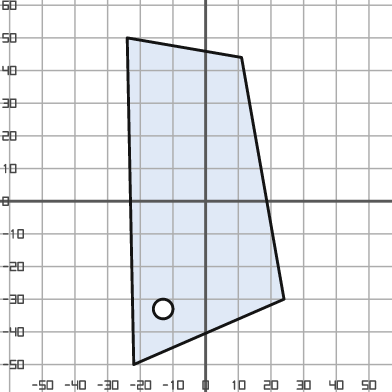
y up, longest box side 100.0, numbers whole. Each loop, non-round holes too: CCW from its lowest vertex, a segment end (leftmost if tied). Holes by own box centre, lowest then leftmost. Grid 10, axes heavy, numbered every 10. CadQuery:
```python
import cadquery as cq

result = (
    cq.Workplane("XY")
    .moveTo(-22.0, -50.0)
    .lineTo(24.0, -30.0)
    .lineTo(11.0, 44.0)
    .lineTo(-24.0, 50.0)
    .close()
    .moveTo(-13.0, -33.0)
    .circle(3.0)
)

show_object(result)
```